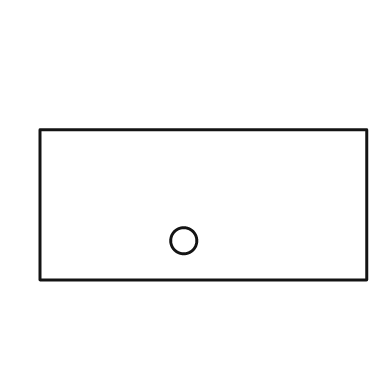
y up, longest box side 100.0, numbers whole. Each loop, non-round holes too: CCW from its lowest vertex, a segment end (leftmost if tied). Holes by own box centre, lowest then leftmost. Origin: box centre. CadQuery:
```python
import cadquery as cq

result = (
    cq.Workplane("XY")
    .moveTo(-50.0, -23.0)
    .lineTo(50.0, -23.0)
    .lineTo(50.0, 23.0)
    .lineTo(-50.0, 23.0)
    .close()
    .moveTo(-6.0, -11.0)
    .circle(4.0)
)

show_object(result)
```